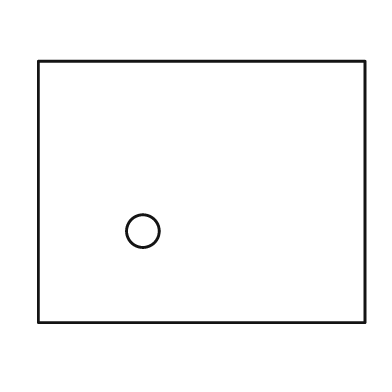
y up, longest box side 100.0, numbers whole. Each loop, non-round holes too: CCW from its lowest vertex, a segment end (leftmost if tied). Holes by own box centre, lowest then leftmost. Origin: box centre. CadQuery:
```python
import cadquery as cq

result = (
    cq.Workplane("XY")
    .moveTo(-50.0, -40.0)
    .lineTo(50.0, -40.0)
    .lineTo(50.0, 40.0)
    .lineTo(-50.0, 40.0)
    .close()
    .moveTo(-18.0, -12.0)
    .circle(5.0)
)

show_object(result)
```